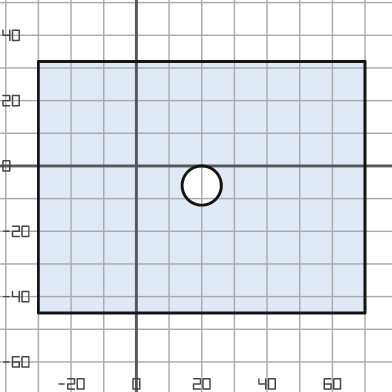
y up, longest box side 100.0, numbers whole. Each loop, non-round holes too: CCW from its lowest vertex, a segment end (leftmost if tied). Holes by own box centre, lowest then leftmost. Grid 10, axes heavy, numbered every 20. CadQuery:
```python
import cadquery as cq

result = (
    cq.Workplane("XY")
    .moveTo(-30.0, -45.0)
    .lineTo(70.0, -45.0)
    .lineTo(70.0, 32.0)
    .lineTo(-30.0, 32.0)
    .close()
    .moveTo(20.0, -6.0)
    .circle(6.0)
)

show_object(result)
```